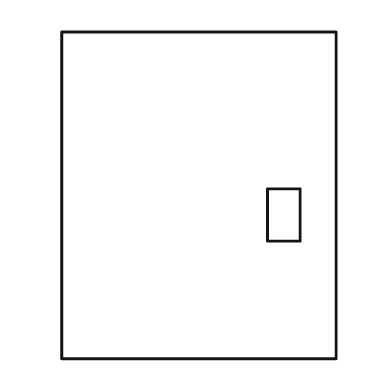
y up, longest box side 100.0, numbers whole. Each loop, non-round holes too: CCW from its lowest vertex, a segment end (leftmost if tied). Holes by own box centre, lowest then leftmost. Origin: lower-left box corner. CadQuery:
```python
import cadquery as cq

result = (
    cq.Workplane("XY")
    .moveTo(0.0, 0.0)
    .lineTo(84.0, 0.0)
    .lineTo(84.0, 100.0)
    .lineTo(0.0, 100.0)
    .close()
    .moveTo(63.0, 36.0)
    .lineTo(73.0, 36.0)
    .lineTo(73.0, 52.0)
    .lineTo(63.0, 52.0)
    .close()
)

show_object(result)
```